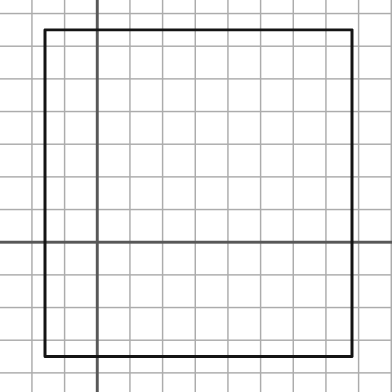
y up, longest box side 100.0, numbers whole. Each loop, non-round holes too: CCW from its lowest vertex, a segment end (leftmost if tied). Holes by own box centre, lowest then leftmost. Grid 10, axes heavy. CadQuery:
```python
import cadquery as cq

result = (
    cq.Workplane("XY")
    .moveTo(-16.0, -35.0)
    .lineTo(78.0, -35.0)
    .lineTo(78.0, 65.0)
    .lineTo(-16.0, 65.0)
    .close()
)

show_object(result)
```